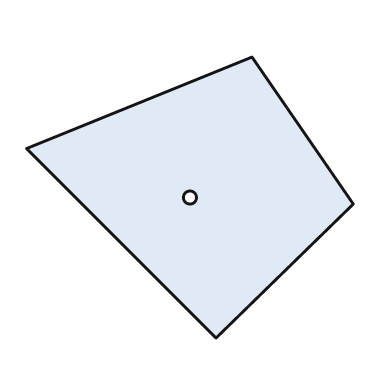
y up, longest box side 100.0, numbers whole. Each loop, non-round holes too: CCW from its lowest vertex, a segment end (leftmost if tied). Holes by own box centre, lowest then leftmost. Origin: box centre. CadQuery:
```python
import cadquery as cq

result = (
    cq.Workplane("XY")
    .moveTo(8.0, -43.0)
    .lineTo(50.0, -2.0)
    .lineTo(19.0, 43.0)
    .lineTo(-50.0, 15.0)
    .close()
    .moveTo(0.0, 0.0)
    .circle(2.0)
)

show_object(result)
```